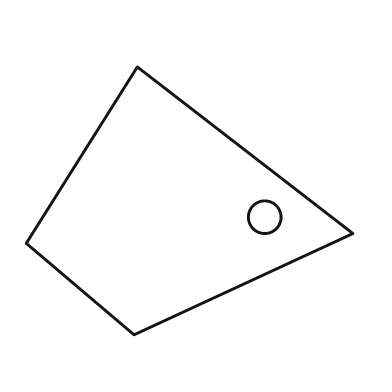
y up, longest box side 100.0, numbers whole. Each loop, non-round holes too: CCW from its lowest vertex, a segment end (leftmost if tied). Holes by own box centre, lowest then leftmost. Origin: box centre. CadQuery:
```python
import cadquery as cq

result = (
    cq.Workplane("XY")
    .moveTo(-17.0, -41.0)
    .lineTo(50.0, -10.0)
    .lineTo(-16.0, 41.0)
    .lineTo(-50.0, -13.0)
    .close()
    .moveTo(23.0, -5.0)
    .circle(5.0)
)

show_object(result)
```